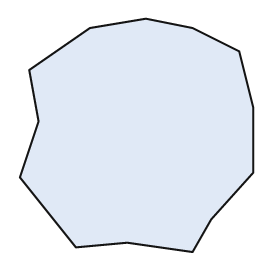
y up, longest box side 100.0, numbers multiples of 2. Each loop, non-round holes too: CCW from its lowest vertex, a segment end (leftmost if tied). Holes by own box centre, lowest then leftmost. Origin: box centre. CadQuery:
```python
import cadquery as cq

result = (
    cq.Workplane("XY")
    .moveTo(24.0, -50.0)
    .lineTo(32.0, -36.0)
    .lineTo(50.0, -16.0)
    .lineTo(50.0, 12.0)
    .lineTo(44.0, 36.0)
    .lineTo(24.0, 46.0)
    .lineTo(4.0, 50.0)
    .lineTo(-20.0, 46.0)
    .lineTo(-46.0, 28.0)
    .lineTo(-42.0, 6.0)
    .lineTo(-50.0, -18.0)
    .lineTo(-26.0, -48.0)
    .lineTo(-4.0, -46.0)
    .close()
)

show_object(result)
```